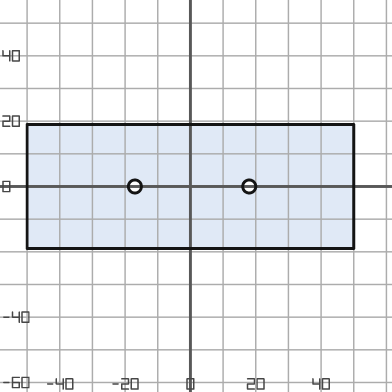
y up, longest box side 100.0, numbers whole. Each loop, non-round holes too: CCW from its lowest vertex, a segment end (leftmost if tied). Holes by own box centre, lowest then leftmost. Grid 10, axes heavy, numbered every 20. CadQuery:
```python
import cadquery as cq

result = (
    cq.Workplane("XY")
    .moveTo(-50.0, -19.0)
    .lineTo(50.0, -19.0)
    .lineTo(50.0, 19.0)
    .lineTo(-50.0, 19.0)
    .close()
    .moveTo(-17.0, 0.0)
    .circle(2.0)
    .moveTo(18.0, 0.0)
    .circle(2.0)
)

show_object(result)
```